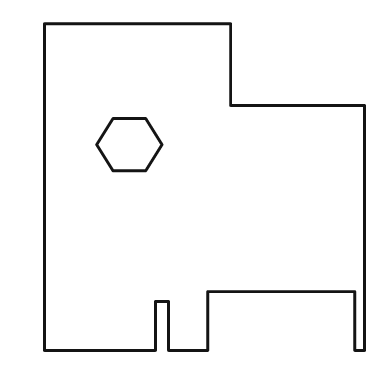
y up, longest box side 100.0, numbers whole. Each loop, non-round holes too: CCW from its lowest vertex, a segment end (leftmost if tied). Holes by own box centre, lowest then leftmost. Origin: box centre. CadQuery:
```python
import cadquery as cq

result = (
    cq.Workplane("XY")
    .moveTo(-49.0, -50.0)
    .lineTo(-15.0, -50.0)
    .lineTo(-15.0, -35.0)
    .lineTo(-11.0, -35.0)
    .lineTo(-11.0, -50.0)
    .lineTo(1.0, -50.0)
    .lineTo(1.0, -32.0)
    .lineTo(46.0, -32.0)
    .lineTo(46.0, -50.0)
    .lineTo(49.0, -50.0)
    .lineTo(49.0, 25.0)
    .lineTo(8.0, 25.0)
    .lineTo(8.0, 50.0)
    .lineTo(-49.0, 50.0)
    .close()
    .moveTo(-28.0, 5.0)
    .lineTo(-18.0, 5.0)
    .lineTo(-13.0, 13.0)
    .lineTo(-18.0, 21.0)
    .lineTo(-28.0, 21.0)
    .lineTo(-33.0, 13.0)
    .close()
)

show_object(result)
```